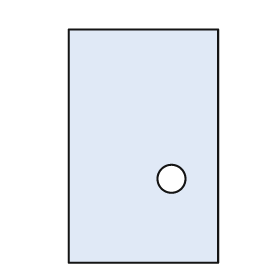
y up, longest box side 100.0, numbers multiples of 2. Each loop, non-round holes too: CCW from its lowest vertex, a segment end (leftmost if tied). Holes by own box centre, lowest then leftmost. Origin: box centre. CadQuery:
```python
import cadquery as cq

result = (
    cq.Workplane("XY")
    .moveTo(-32.0, -50.0)
    .lineTo(32.0, -50.0)
    .lineTo(32.0, 50.0)
    .lineTo(-32.0, 50.0)
    .close()
    .moveTo(12.0, -14.0)
    .circle(6.0)
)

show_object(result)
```